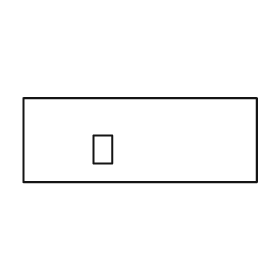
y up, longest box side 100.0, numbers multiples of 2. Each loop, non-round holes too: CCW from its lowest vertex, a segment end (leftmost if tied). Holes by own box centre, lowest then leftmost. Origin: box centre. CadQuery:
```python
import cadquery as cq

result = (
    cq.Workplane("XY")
    .moveTo(-50.0, -18.0)
    .lineTo(50.0, -18.0)
    .lineTo(50.0, 18.0)
    .lineTo(-50.0, 18.0)
    .close()
    .moveTo(-20.0, -10.0)
    .lineTo(-12.0, -10.0)
    .lineTo(-12.0, 2.0)
    .lineTo(-20.0, 2.0)
    .close()
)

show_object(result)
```